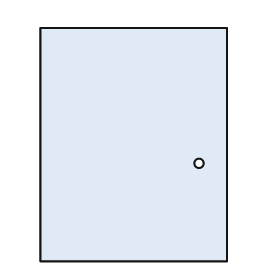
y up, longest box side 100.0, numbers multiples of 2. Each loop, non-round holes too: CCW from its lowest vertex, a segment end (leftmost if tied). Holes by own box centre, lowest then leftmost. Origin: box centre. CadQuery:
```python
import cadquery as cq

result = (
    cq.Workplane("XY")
    .moveTo(-40.0, -50.0)
    .lineTo(40.0, -50.0)
    .lineTo(40.0, 50.0)
    .lineTo(-40.0, 50.0)
    .close()
    .moveTo(28.0, -8.0)
    .circle(2.0)
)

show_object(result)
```